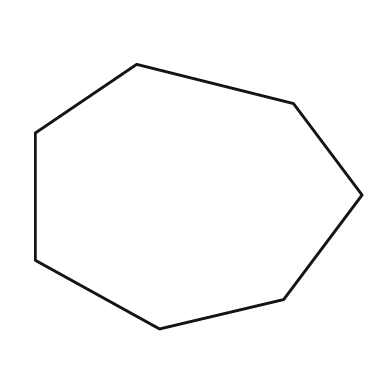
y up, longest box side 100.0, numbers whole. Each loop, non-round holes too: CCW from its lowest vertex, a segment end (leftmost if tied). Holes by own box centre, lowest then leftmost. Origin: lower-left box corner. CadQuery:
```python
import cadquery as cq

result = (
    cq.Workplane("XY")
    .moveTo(38.0, 0.0)
    .lineTo(76.0, 9.0)
    .lineTo(100.0, 41.0)
    .lineTo(79.0, 69.0)
    .lineTo(31.0, 81.0)
    .lineTo(0.0, 60.0)
    .lineTo(0.0, 21.0)
    .close()
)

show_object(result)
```